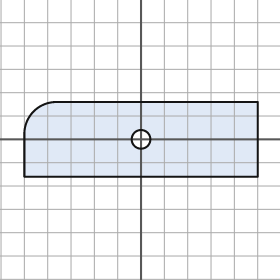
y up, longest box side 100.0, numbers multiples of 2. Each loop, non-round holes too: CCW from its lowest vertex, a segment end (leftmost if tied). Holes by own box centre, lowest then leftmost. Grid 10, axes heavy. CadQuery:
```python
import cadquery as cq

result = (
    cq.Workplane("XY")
    .moveTo(-50.0, -16.0)
    .lineTo(50.0, -16.0)
    .lineTo(50.0, 16.0)
    .lineTo(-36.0, 16.0)
    .threePointArc((-46.0, 12.0), (-50.0, 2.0))
    .close()
    .moveTo(0.0, 0.0)
    .circle(4.0)
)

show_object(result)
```